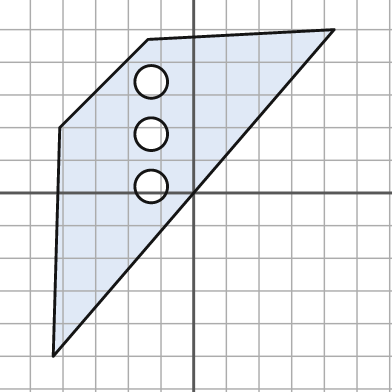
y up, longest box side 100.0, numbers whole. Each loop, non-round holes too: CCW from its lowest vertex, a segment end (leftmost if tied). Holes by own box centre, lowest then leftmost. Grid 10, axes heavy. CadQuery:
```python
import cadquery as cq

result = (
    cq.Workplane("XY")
    .moveTo(-43.0, -50.0)
    .lineTo(43.0, 50.0)
    .lineTo(-14.0, 47.0)
    .lineTo(-41.0, 20.0)
    .close()
    .moveTo(-13.0, 2.0)
    .circle(5.0)
    .moveTo(-13.0, 18.0)
    .circle(5.0)
    .moveTo(-13.0, 34.0)
    .circle(5.0)
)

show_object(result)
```